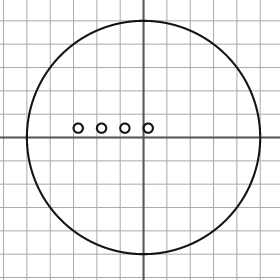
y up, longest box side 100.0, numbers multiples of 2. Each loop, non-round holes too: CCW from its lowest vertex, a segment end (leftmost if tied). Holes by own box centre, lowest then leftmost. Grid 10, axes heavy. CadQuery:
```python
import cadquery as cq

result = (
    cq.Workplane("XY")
    .moveTo(0.0, 0.0)
    .circle(50.0)
    .moveTo(-28.0, 4.0)
    .circle(2.0)
    .moveTo(-18.0, 4.0)
    .circle(2.0)
    .moveTo(-8.0, 4.0)
    .circle(2.0)
    .moveTo(2.0, 4.0)
    .circle(2.0)
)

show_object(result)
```